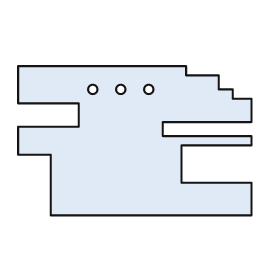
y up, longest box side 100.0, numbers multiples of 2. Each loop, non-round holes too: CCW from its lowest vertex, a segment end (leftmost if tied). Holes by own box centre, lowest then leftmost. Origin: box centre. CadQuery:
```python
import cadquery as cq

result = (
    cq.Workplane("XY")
    .moveTo(-36.0, -32.0)
    .lineTo(50.0, -32.0)
    .lineTo(50.0, -18.0)
    .lineTo(20.0, -18.0)
    .lineTo(20.0, -2.0)
    .lineTo(50.0, -2.0)
    .lineTo(50.0, 2.0)
    .lineTo(12.0, 2.0)
    .lineTo(12.0, 8.0)
    .lineTo(50.0, 8.0)
    .lineTo(50.0, 18.0)
    .lineTo(42.0, 18.0)
    .lineTo(42.0, 22.0)
    .lineTo(36.0, 22.0)
    .lineTo(36.0, 28.0)
    .lineTo(22.0, 28.0)
    .lineTo(22.0, 32.0)
    .lineTo(-50.0, 32.0)
    .lineTo(-50.0, 16.0)
    .lineTo(-24.0, 16.0)
    .lineTo(-24.0, 6.0)
    .lineTo(-50.0, 6.0)
    .lineTo(-50.0, -6.0)
    .lineTo(-36.0, -6.0)
    .close()
    .moveTo(-18.0, 22.0)
    .circle(2.0)
    .moveTo(-6.0, 22.0)
    .circle(2.0)
    .moveTo(6.0, 22.0)
    .circle(2.0)
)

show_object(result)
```